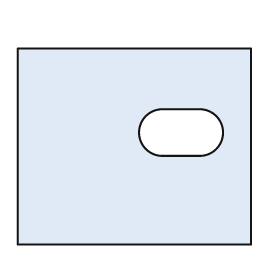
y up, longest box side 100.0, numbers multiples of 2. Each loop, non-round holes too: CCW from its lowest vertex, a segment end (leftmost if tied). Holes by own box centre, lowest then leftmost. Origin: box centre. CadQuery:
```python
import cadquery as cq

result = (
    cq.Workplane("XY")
    .moveTo(-50.0, -42.0)
    .lineTo(50.0, -42.0)
    .lineTo(50.0, 42.0)
    .lineTo(-50.0, 42.0)
    .close()
    .moveTo(12.0, -4.0)
    .lineTo(28.0, -4.0)
    .threePointArc((38.0, 6.0), (28.0, 16.0))
    .lineTo(12.0, 16.0)
    .threePointArc((2.0, 6.0), (12.0, -4.0))
    .close()
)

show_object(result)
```